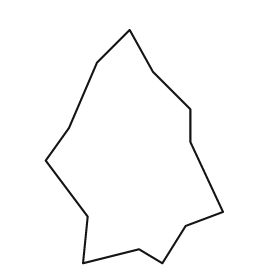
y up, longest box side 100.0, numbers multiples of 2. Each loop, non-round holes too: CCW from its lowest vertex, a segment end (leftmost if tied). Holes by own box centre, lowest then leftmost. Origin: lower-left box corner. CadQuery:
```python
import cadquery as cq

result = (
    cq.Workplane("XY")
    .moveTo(16.0, 0.0)
    .lineTo(40.0, 6.0)
    .lineTo(50.0, 0.0)
    .lineTo(60.0, 16.0)
    .lineTo(76.0, 22.0)
    .lineTo(62.0, 52.0)
    .lineTo(62.0, 66.0)
    .lineTo(46.0, 82.0)
    .lineTo(36.0, 100.0)
    .lineTo(22.0, 86.0)
    .lineTo(10.0, 58.0)
    .lineTo(0.0, 44.0)
    .lineTo(18.0, 20.0)
    .close()
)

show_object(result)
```